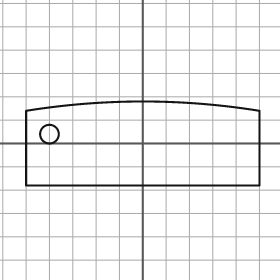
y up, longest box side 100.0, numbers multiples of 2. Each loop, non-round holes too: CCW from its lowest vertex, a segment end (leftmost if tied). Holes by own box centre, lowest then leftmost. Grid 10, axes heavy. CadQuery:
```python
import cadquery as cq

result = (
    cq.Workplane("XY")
    .moveTo(-50.0, -18.0)
    .lineTo(50.0, -18.0)
    .lineTo(50.0, 14.0)
    .threePointArc((0.0, 18.0), (-50.0, 14.0))
    .close()
    .moveTo(-40.0, 4.0)
    .circle(4.0)
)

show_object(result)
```